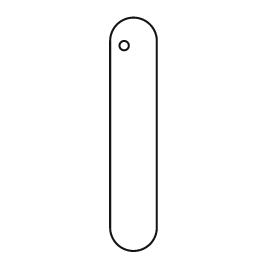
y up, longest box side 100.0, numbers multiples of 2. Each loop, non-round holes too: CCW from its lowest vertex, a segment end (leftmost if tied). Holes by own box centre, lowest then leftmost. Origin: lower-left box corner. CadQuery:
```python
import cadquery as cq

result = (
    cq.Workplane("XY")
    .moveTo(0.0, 10.0)
    .threePointArc((10.0, 0.0), (20.0, 10.0))
    .lineTo(20.0, 90.0)
    .threePointArc((10.0, 100.0), (0.0, 90.0))
    .close()
    .moveTo(6.0, 88.0)
    .circle(2.0)
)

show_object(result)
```